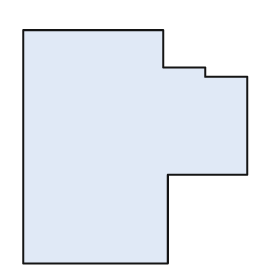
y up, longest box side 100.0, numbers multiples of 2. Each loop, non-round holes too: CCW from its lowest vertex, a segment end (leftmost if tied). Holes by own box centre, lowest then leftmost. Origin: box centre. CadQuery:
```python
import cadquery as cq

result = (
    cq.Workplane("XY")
    .moveTo(-48.0, -50.0)
    .lineTo(14.0, -50.0)
    .lineTo(14.0, -12.0)
    .lineTo(48.0, -12.0)
    .lineTo(48.0, 30.0)
    .lineTo(30.0, 30.0)
    .lineTo(30.0, 34.0)
    .lineTo(12.0, 34.0)
    .lineTo(12.0, 50.0)
    .lineTo(-48.0, 50.0)
    .close()
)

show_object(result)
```